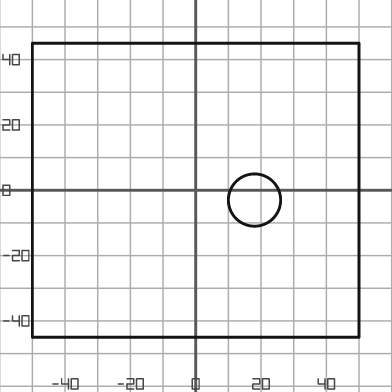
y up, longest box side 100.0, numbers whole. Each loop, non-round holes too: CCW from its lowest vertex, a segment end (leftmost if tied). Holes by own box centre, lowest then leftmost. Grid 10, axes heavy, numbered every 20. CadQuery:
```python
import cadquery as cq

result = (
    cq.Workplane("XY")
    .moveTo(-50.0, -45.0)
    .lineTo(50.0, -45.0)
    .lineTo(50.0, 45.0)
    .lineTo(-50.0, 45.0)
    .close()
    .moveTo(18.0, -3.0)
    .circle(8.0)
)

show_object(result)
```